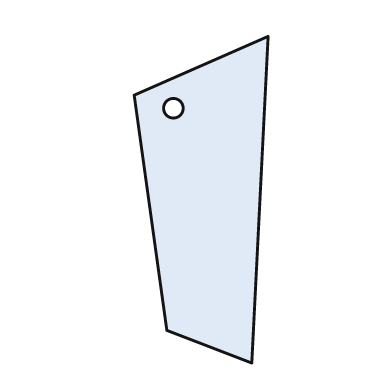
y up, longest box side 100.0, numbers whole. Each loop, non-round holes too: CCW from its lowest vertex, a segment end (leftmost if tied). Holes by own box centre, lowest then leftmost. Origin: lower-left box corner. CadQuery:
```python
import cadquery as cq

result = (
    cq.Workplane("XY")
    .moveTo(36.0, 0.0)
    .lineTo(41.0, 100.0)
    .lineTo(0.0, 82.0)
    .lineTo(10.0, 10.0)
    .close()
    .moveTo(12.0, 78.0)
    .circle(3.0)
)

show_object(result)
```